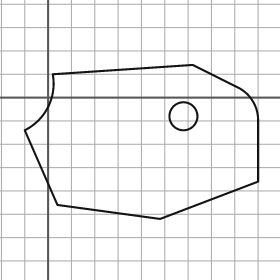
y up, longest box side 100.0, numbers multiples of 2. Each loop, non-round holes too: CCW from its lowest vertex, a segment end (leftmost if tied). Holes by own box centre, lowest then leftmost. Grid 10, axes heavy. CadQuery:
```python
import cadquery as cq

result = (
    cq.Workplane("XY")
    .moveTo(48.0, -52.0)
    .lineTo(90.0, -36.0)
    .lineTo(90.0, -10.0)
    .threePointArc((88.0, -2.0), (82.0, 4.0))
    .lineTo(62.0, 14.0)
    .lineTo(2.0, 10.0)
    .threePointArc((0.0, -4.0), (-10.0, -14.0))
    .lineTo(4.0, -46.0)
    .close()
    .moveTo(58.0, -8.0)
    .circle(6.0)
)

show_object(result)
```